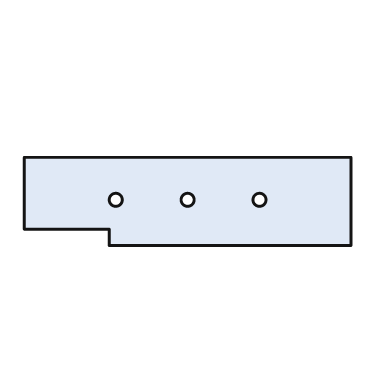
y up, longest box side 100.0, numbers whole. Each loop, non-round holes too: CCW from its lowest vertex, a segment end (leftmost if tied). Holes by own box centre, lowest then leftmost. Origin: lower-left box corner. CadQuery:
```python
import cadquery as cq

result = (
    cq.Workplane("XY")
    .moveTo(26.0, 0.0)
    .lineTo(100.0, 0.0)
    .lineTo(100.0, 27.0)
    .lineTo(0.0, 27.0)
    .lineTo(0.0, 5.0)
    .lineTo(26.0, 5.0)
    .close()
    .moveTo(28.0, 14.0)
    .circle(2.0)
    .moveTo(50.0, 14.0)
    .circle(2.0)
    .moveTo(72.0, 14.0)
    .circle(2.0)
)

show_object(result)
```